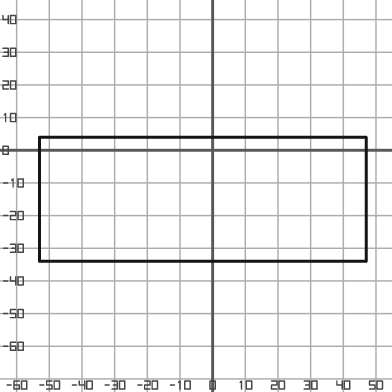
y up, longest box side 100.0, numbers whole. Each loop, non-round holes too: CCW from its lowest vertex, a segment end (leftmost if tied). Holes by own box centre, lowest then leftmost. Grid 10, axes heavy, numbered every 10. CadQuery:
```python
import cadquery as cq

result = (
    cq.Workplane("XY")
    .moveTo(-53.0, -34.0)
    .lineTo(47.0, -34.0)
    .lineTo(47.0, 4.0)
    .lineTo(-53.0, 4.0)
    .close()
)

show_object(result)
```